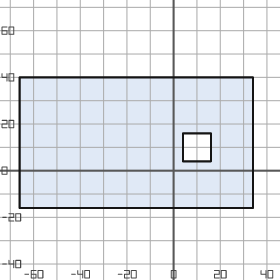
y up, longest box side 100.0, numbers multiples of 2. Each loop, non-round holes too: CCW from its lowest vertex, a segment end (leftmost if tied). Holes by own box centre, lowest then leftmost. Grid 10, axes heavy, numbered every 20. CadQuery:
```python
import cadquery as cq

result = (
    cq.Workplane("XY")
    .moveTo(-66.0, -16.0)
    .lineTo(34.0, -16.0)
    .lineTo(34.0, 40.0)
    .lineTo(-66.0, 40.0)
    .close()
    .moveTo(4.0, 4.0)
    .lineTo(16.0, 4.0)
    .lineTo(16.0, 16.0)
    .lineTo(4.0, 16.0)
    .close()
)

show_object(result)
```